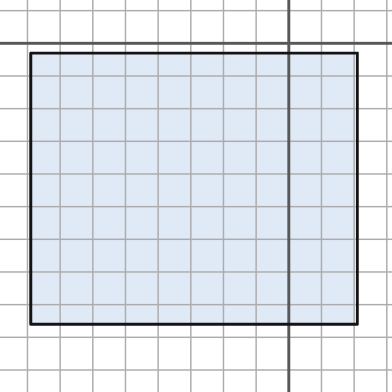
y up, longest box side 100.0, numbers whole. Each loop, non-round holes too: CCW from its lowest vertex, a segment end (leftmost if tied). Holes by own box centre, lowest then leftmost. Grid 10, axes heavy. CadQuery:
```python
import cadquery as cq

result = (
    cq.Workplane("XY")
    .moveTo(-79.0, -86.0)
    .lineTo(21.0, -86.0)
    .lineTo(21.0, -3.0)
    .lineTo(-79.0, -3.0)
    .close()
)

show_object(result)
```